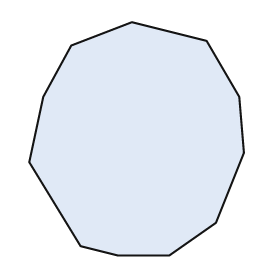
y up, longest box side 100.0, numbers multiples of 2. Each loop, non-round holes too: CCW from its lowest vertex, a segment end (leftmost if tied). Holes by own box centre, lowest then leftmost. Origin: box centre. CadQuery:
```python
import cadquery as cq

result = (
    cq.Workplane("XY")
    .moveTo(-8.0, -50.0)
    .lineTo(14.0, -50.0)
    .lineTo(34.0, -36.0)
    .lineTo(46.0, -6.0)
    .lineTo(44.0, 18.0)
    .lineTo(30.0, 42.0)
    .lineTo(-2.0, 50.0)
    .lineTo(-28.0, 40.0)
    .lineTo(-40.0, 18.0)
    .lineTo(-46.0, -10.0)
    .lineTo(-24.0, -46.0)
    .close()
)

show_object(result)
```